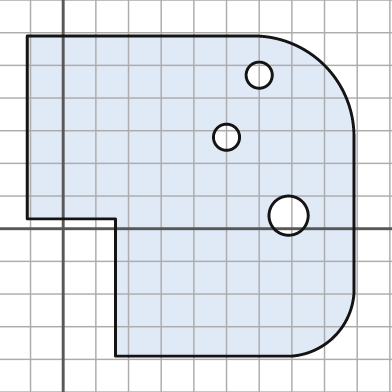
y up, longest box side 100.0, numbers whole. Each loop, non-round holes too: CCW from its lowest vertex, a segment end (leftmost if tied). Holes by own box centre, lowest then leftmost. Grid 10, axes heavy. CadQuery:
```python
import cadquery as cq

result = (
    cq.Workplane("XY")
    .moveTo(16.0, -39.0)
    .lineTo(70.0, -39.0)
    .threePointArc((83.0, -33.0), (89.0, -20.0))
    .lineTo(89.0, 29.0)
    .threePointArc((80.0, 50.0), (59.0, 59.0))
    .lineTo(-11.0, 59.0)
    .lineTo(-11.0, 3.0)
    .lineTo(16.0, 3.0)
    .close()
    .moveTo(69.0, 4.0)
    .circle(6.0)
    .moveTo(50.0, 28.0)
    .circle(4.0)
    .moveTo(60.0, 47.0)
    .circle(4.0)
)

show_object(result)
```